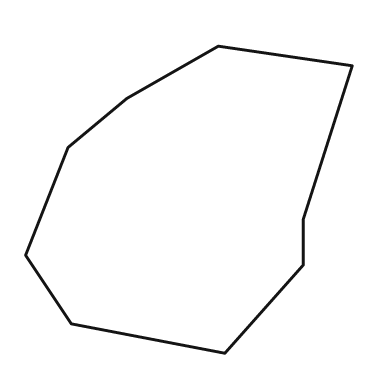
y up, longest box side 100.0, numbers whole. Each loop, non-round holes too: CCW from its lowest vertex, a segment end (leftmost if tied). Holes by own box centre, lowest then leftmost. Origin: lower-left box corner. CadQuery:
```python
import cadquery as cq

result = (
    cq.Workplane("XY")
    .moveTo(61.0, 0.0)
    .lineTo(85.0, 27.0)
    .lineTo(85.0, 41.0)
    .lineTo(100.0, 88.0)
    .lineTo(59.0, 94.0)
    .lineTo(31.0, 78.0)
    .lineTo(13.0, 63.0)
    .lineTo(0.0, 30.0)
    .lineTo(14.0, 9.0)
    .close()
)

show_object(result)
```